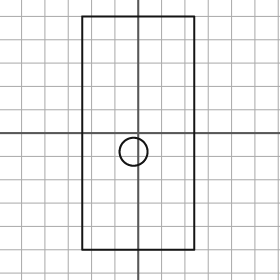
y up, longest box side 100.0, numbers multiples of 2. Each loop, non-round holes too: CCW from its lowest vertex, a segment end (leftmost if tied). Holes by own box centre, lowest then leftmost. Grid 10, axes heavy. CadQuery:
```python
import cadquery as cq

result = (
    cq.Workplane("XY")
    .moveTo(-24.0, -50.0)
    .lineTo(24.0, -50.0)
    .lineTo(24.0, 50.0)
    .lineTo(-24.0, 50.0)
    .close()
    .moveTo(-2.0, -8.0)
    .circle(6.0)
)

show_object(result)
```